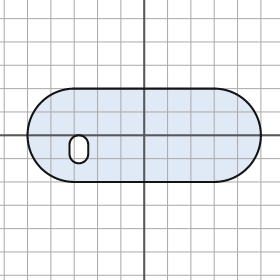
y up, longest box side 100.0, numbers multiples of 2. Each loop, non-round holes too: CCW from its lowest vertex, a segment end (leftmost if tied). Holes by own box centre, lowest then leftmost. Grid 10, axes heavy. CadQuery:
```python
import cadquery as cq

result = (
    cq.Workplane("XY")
    .moveTo(-30.0, -20.0)
    .lineTo(30.0, -20.0)
    .threePointArc((50.0, 0.0), (30.0, 20.0))
    .lineTo(-30.0, 20.0)
    .threePointArc((-50.0, 0.0), (-30.0, -20.0))
    .close()
    .moveTo(-32.0, -8.0)
    .threePointArc((-28.0, -12.0), (-24.0, -8.0))
    .lineTo(-24.0, -4.0)
    .threePointArc((-28.0, 0.0), (-32.0, -4.0))
    .close()
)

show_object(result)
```